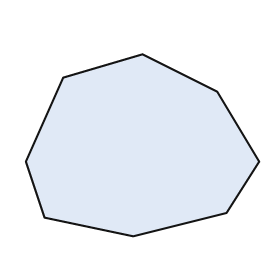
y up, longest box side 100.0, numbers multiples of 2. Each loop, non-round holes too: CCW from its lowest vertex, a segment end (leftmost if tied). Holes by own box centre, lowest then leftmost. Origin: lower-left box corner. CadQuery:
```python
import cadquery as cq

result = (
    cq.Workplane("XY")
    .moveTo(46.0, 0.0)
    .lineTo(86.0, 10.0)
    .lineTo(100.0, 32.0)
    .lineTo(82.0, 62.0)
    .lineTo(50.0, 78.0)
    .lineTo(16.0, 68.0)
    .lineTo(0.0, 32.0)
    .lineTo(8.0, 8.0)
    .close()
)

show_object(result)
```